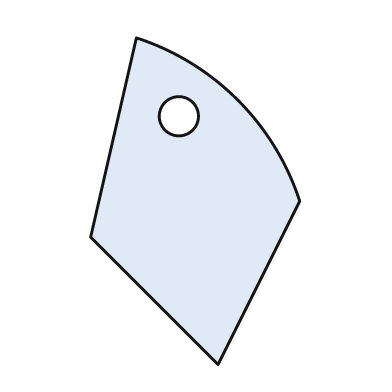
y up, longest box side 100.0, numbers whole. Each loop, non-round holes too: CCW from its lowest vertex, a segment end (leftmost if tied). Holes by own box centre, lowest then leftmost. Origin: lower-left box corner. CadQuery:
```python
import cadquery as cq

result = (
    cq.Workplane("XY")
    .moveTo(39.0, 0.0)
    .lineTo(64.0, 50.0)
    .threePointArc((45.0, 81.0), (14.0, 100.0))
    .lineTo(0.0, 39.0)
    .close()
    .moveTo(27.0, 76.0)
    .circle(6.0)
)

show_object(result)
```